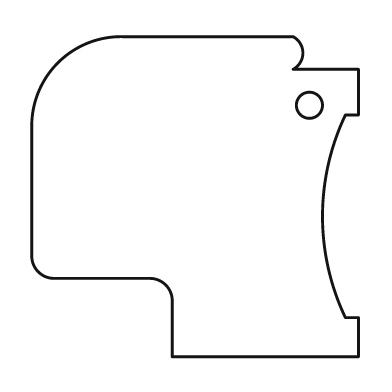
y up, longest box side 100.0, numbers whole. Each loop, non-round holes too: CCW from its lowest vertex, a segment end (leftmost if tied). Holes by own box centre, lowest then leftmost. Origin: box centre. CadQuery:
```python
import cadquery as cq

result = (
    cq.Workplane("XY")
    .moveTo(-7.0, -49.0)
    .lineTo(50.0, -49.0)
    .lineTo(50.0, -37.0)
    .lineTo(46.0, -37.0)
    .threePointArc((39.0, -6.0), (46.0, 25.0))
    .lineTo(50.0, 25.0)
    .lineTo(50.0, 39.0)
    .lineTo(30.0, 39.0)
    .threePointArc((33.0, 44.0), (30.0, 49.0))
    .lineTo(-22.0, 49.0)
    .threePointArc((-42.0, 41.0), (-50.0, 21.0))
    .lineTo(-50.0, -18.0)
    .threePointArc((-48.0, -23.0), (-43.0, -25.0))
    .lineTo(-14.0, -25.0)
    .threePointArc((-9.0, -27.0), (-7.0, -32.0))
    .close()
    .moveTo(35.0, 28.0)
    .circle(4.0)
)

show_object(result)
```